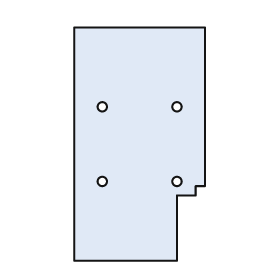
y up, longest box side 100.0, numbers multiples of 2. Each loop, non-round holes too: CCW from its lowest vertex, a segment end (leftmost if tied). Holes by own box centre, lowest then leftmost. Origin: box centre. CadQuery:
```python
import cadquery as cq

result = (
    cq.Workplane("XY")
    .moveTo(-28.0, -50.0)
    .lineTo(16.0, -50.0)
    .lineTo(16.0, -22.0)
    .lineTo(24.0, -22.0)
    .lineTo(24.0, -18.0)
    .lineTo(28.0, -18.0)
    .lineTo(28.0, 50.0)
    .lineTo(-28.0, 50.0)
    .close()
    .moveTo(-16.0, -16.0)
    .circle(2.0)
    .moveTo(16.0, -16.0)
    .circle(2.0)
    .moveTo(-16.0, 16.0)
    .circle(2.0)
    .moveTo(16.0, 16.0)
    .circle(2.0)
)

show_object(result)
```